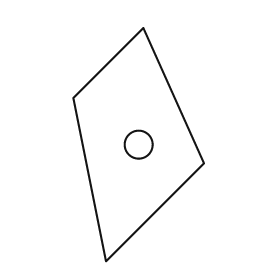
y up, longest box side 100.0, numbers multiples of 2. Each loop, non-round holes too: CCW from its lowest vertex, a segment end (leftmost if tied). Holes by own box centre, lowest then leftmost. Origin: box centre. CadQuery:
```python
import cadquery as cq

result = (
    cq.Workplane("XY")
    .moveTo(-14.0, -50.0)
    .lineTo(28.0, -8.0)
    .lineTo(2.0, 50.0)
    .lineTo(-28.0, 20.0)
    .close()
    .moveTo(0.0, 0.0)
    .circle(6.0)
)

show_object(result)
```